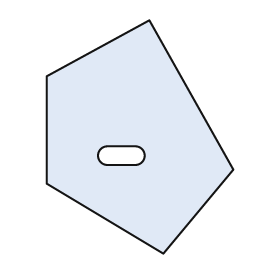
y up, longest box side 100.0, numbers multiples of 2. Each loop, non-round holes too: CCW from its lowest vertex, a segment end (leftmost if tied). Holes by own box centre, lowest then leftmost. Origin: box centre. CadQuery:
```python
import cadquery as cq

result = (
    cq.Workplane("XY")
    .moveTo(10.0, -50.0)
    .lineTo(40.0, -14.0)
    .lineTo(4.0, 50.0)
    .lineTo(-40.0, 26.0)
    .lineTo(-40.0, -20.0)
    .close()
    .moveTo(-14.0, -12.0)
    .lineTo(-2.0, -12.0)
    .threePointArc((2.0, -8.0), (-2.0, -4.0))
    .lineTo(-14.0, -4.0)
    .threePointArc((-18.0, -8.0), (-14.0, -12.0))
    .close()
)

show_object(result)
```